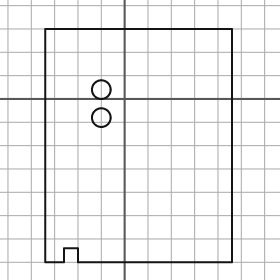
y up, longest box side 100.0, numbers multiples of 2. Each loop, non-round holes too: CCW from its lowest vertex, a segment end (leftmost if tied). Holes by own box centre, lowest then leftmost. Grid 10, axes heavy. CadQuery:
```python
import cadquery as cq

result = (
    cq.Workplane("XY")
    .moveTo(-34.0, -70.0)
    .lineTo(-26.0, -70.0)
    .lineTo(-26.0, -64.0)
    .lineTo(-20.0, -64.0)
    .lineTo(-20.0, -70.0)
    .lineTo(46.0, -70.0)
    .lineTo(46.0, 30.0)
    .lineTo(-34.0, 30.0)
    .close()
    .moveTo(-10.0, -8.0)
    .circle(4.0)
    .moveTo(-10.0, 4.0)
    .circle(4.0)
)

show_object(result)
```